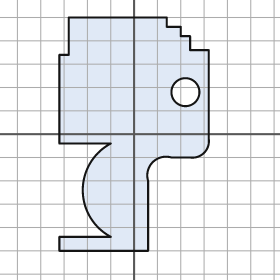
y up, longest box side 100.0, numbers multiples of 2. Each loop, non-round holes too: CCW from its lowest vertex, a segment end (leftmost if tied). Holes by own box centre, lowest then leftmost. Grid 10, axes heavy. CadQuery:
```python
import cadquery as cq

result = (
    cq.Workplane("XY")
    .moveTo(-32.0, -50.0)
    .lineTo(6.0, -50.0)
    .lineTo(6.0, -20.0)
    .threePointArc((8.0, -12.0), (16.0, -10.0))
    .lineTo(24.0, -10.0)
    .threePointArc((30.0, -8.0), (32.0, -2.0))
    .lineTo(32.0, 36.0)
    .lineTo(24.0, 36.0)
    .lineTo(24.0, 42.0)
    .lineTo(20.0, 42.0)
    .lineTo(20.0, 46.0)
    .lineTo(14.0, 46.0)
    .lineTo(14.0, 50.0)
    .lineTo(-28.0, 50.0)
    .lineTo(-28.0, 34.0)
    .lineTo(-32.0, 34.0)
    .lineTo(-32.0, -4.0)
    .lineTo(-10.0, -4.0)
    .threePointArc((-22.0, -24.0), (-10.0, -44.0))
    .lineTo(-32.0, -44.0)
    .close()
    .moveTo(22.0, 18.0)
    .circle(6.0)
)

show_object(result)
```